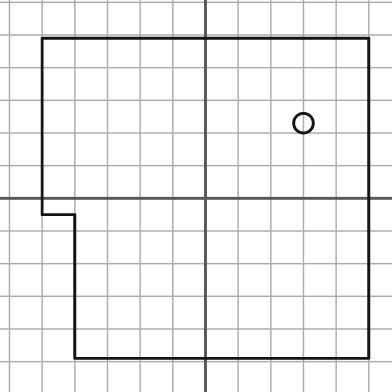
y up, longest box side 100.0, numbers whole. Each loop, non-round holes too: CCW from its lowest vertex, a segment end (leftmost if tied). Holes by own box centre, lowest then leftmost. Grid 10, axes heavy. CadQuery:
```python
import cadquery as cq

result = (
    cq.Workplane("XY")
    .moveTo(-40.0, -49.0)
    .lineTo(50.0, -49.0)
    .lineTo(50.0, 49.0)
    .lineTo(-50.0, 49.0)
    .lineTo(-50.0, -5.0)
    .lineTo(-40.0, -5.0)
    .close()
    .moveTo(30.0, 23.0)
    .circle(3.0)
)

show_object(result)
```